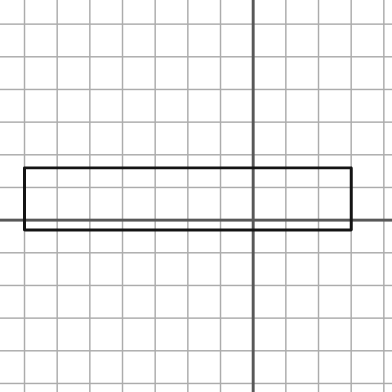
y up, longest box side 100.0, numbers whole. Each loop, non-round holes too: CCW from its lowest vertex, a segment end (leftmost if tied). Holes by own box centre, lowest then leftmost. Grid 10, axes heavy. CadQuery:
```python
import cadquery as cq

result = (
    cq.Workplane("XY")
    .moveTo(-70.0, -3.0)
    .lineTo(30.0, -3.0)
    .lineTo(30.0, 16.0)
    .lineTo(-70.0, 16.0)
    .close()
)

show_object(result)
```